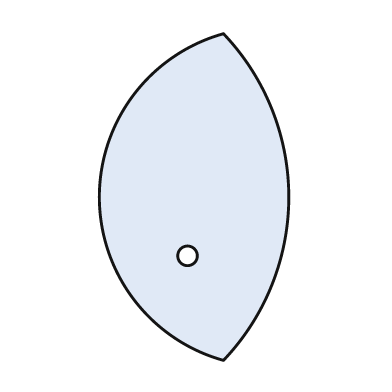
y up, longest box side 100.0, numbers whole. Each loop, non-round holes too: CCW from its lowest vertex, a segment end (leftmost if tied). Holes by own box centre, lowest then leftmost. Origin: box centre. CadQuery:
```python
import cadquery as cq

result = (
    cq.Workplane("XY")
    .moveTo(9.0, -50.0)
    .threePointArc((29.0, 0.0), (9.0, 50.0))
    .threePointArc((-29.0, 0.0), (9.0, -50.0))
    .close()
    .moveTo(-2.0, -18.0)
    .circle(3.0)
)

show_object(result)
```